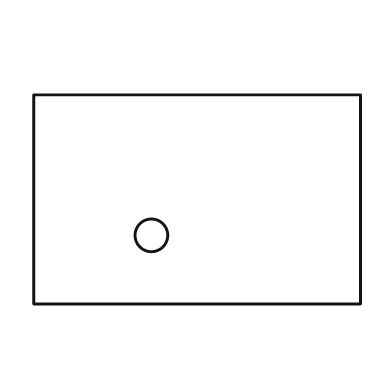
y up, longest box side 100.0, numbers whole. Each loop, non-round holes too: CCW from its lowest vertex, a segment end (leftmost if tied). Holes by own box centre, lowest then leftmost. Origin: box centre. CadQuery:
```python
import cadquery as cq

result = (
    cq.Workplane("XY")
    .moveTo(-50.0, -32.0)
    .lineTo(50.0, -32.0)
    .lineTo(50.0, 32.0)
    .lineTo(-50.0, 32.0)
    .close()
    .moveTo(-14.0, -11.0)
    .circle(5.0)
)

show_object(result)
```